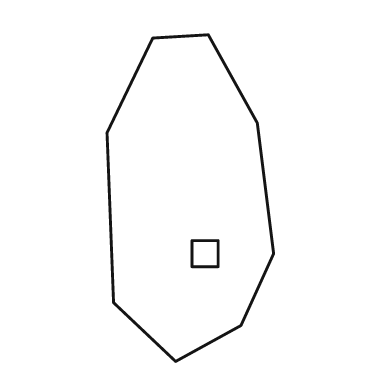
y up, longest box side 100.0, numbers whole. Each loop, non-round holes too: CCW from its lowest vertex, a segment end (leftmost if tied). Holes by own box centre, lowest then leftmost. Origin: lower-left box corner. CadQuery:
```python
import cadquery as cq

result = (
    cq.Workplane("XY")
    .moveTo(21.0, 0.0)
    .lineTo(41.0, 11.0)
    .lineTo(51.0, 33.0)
    .lineTo(46.0, 73.0)
    .lineTo(31.0, 100.0)
    .lineTo(14.0, 99.0)
    .lineTo(0.0, 70.0)
    .lineTo(2.0, 18.0)
    .close()
    .moveTo(26.0, 29.0)
    .lineTo(34.0, 29.0)
    .lineTo(34.0, 37.0)
    .lineTo(26.0, 37.0)
    .close()
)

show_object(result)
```